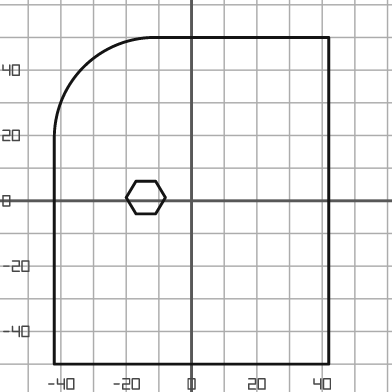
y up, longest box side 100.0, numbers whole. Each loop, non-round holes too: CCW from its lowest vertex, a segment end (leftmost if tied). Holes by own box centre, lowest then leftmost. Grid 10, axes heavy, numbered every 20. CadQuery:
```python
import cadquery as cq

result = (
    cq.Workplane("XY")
    .moveTo(-42.0, -50.0)
    .lineTo(42.0, -50.0)
    .lineTo(42.0, 50.0)
    .lineTo(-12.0, 50.0)
    .threePointArc((-33.0, 41.0), (-42.0, 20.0))
    .close()
    .moveTo(-17.0, -4.0)
    .lineTo(-11.0, -4.0)
    .lineTo(-8.0, 1.0)
    .lineTo(-11.0, 6.0)
    .lineTo(-17.0, 6.0)
    .lineTo(-20.0, 1.0)
    .close()
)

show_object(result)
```